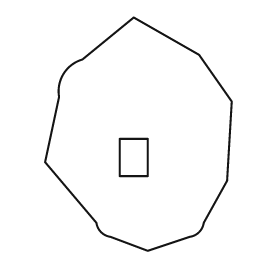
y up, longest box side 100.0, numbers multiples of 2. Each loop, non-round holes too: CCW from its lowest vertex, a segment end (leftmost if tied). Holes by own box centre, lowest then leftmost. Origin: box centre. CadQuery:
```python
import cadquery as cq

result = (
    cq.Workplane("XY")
    .moveTo(4.0, -50.0)
    .lineTo(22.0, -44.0)
    .threePointArc((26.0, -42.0), (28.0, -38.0))
    .lineTo(38.0, -20.0)
    .lineTo(40.0, 14.0)
    .lineTo(26.0, 34.0)
    .lineTo(-2.0, 50.0)
    .lineTo(-24.0, 32.0)
    .threePointArc((-32.0, 26.0), (-34.0, 16.0))
    .lineTo(-40.0, -12.0)
    .lineTo(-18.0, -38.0)
    .threePointArc((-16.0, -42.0), (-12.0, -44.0))
    .close()
    .moveTo(-8.0, -18.0)
    .lineTo(4.0, -18.0)
    .lineTo(4.0, -2.0)
    .lineTo(-8.0, -2.0)
    .close()
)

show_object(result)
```